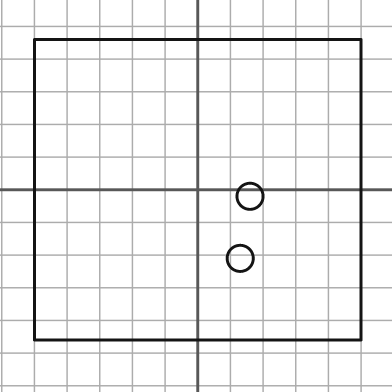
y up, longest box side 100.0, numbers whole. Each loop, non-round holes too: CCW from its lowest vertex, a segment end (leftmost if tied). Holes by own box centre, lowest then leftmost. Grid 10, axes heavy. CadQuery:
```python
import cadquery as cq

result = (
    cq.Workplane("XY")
    .moveTo(-50.0, -46.0)
    .lineTo(50.0, -46.0)
    .lineTo(50.0, 46.0)
    .lineTo(-50.0, 46.0)
    .close()
    .moveTo(13.0, -21.0)
    .circle(4.0)
    .moveTo(16.0, -2.0)
    .circle(4.0)
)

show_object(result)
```